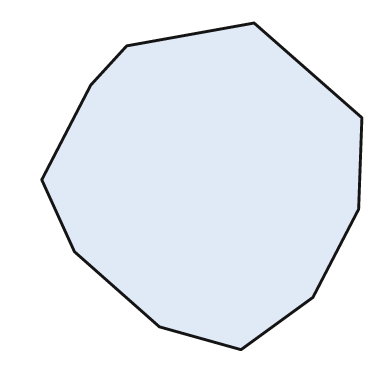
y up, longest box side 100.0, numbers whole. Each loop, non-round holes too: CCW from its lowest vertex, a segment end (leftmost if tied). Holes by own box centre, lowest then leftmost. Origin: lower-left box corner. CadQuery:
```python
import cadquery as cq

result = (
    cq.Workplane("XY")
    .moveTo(61.0, 0.0)
    .lineTo(83.0, 16.0)
    .lineTo(97.0, 43.0)
    .lineTo(98.0, 71.0)
    .lineTo(65.0, 100.0)
    .lineTo(26.0, 93.0)
    .lineTo(15.0, 81.0)
    .lineTo(0.0, 52.0)
    .lineTo(10.0, 30.0)
    .lineTo(36.0, 7.0)
    .close()
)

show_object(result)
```